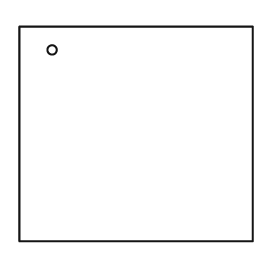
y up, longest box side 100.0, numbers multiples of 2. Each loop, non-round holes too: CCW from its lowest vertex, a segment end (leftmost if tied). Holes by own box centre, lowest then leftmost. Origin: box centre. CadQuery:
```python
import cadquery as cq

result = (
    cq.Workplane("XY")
    .moveTo(-50.0, -46.0)
    .lineTo(50.0, -46.0)
    .lineTo(50.0, 46.0)
    .lineTo(-50.0, 46.0)
    .close()
    .moveTo(-36.0, 36.0)
    .circle(2.0)
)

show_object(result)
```